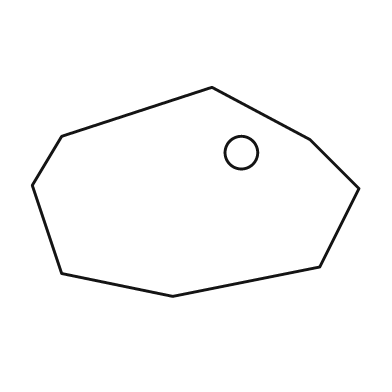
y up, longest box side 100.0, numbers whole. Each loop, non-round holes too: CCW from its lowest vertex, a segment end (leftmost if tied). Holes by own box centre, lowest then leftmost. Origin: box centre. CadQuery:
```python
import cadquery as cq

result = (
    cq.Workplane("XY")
    .moveTo(-7.0, -32.0)
    .lineTo(38.0, -23.0)
    .lineTo(50.0, 1.0)
    .lineTo(35.0, 16.0)
    .lineTo(5.0, 32.0)
    .lineTo(-41.0, 17.0)
    .lineTo(-50.0, 2.0)
    .lineTo(-41.0, -25.0)
    .close()
    .moveTo(14.0, 12.0)
    .circle(5.0)
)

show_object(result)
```